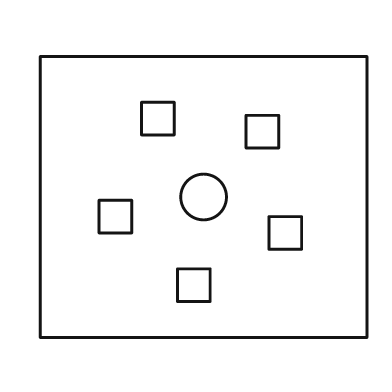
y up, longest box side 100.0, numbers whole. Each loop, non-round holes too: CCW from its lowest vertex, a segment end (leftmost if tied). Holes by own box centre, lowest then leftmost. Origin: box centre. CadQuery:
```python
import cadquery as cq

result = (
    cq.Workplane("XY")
    .moveTo(-50.0, -43.0)
    .lineTo(50.0, -43.0)
    .lineTo(50.0, 43.0)
    .lineTo(-50.0, 43.0)
    .close()
    .moveTo(-8.0, -32.0)
    .lineTo(2.0, -32.0)
    .lineTo(2.0, -22.0)
    .lineTo(-8.0, -22.0)
    .close()
    .moveTo(20.0, -16.0)
    .lineTo(30.0, -16.0)
    .lineTo(30.0, -6.0)
    .lineTo(20.0, -6.0)
    .close()
    .moveTo(-32.0, -11.0)
    .lineTo(-22.0, -11.0)
    .lineTo(-22.0, -1.0)
    .lineTo(-32.0, -1.0)
    .close()
    .moveTo(0.0, 0.0)
    .circle(7.0)
    .moveTo(13.0, 15.0)
    .lineTo(23.0, 15.0)
    .lineTo(23.0, 25.0)
    .lineTo(13.0, 25.0)
    .close()
    .moveTo(-19.0, 19.0)
    .lineTo(-9.0, 19.0)
    .lineTo(-9.0, 29.0)
    .lineTo(-19.0, 29.0)
    .close()
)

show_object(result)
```